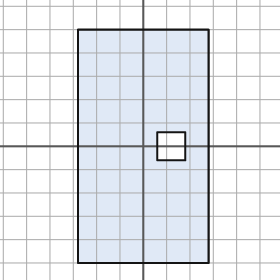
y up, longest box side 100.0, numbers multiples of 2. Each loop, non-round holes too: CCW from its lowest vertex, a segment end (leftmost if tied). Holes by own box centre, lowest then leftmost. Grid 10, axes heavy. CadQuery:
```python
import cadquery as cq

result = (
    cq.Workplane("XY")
    .moveTo(-28.0, -50.0)
    .lineTo(28.0, -50.0)
    .lineTo(28.0, 50.0)
    .lineTo(-28.0, 50.0)
    .close()
    .moveTo(6.0, -6.0)
    .lineTo(18.0, -6.0)
    .lineTo(18.0, 6.0)
    .lineTo(6.0, 6.0)
    .close()
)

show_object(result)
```